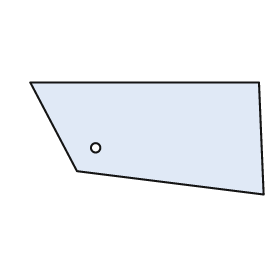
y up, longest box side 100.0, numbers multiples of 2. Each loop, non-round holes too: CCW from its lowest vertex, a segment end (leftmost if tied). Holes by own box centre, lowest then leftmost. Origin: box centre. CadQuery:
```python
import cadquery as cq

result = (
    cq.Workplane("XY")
    .moveTo(50.0, -24.0)
    .lineTo(48.0, 24.0)
    .lineTo(-50.0, 24.0)
    .lineTo(-30.0, -14.0)
    .close()
    .moveTo(-22.0, -4.0)
    .circle(2.0)
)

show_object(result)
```